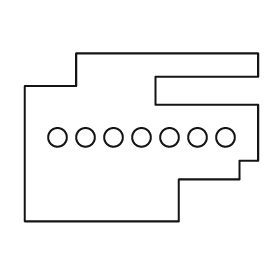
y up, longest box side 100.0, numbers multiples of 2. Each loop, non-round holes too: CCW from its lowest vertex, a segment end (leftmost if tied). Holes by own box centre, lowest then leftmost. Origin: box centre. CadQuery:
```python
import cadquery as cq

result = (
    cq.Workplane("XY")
    .moveTo(-50.0, -36.0)
    .lineTo(16.0, -36.0)
    .lineTo(16.0, -18.0)
    .lineTo(42.0, -18.0)
    .lineTo(42.0, -10.0)
    .lineTo(50.0, -10.0)
    .lineTo(50.0, 14.0)
    .lineTo(6.0, 14.0)
    .lineTo(6.0, 26.0)
    .lineTo(50.0, 26.0)
    .lineTo(50.0, 36.0)
    .lineTo(-28.0, 36.0)
    .lineTo(-28.0, 22.0)
    .lineTo(-50.0, 22.0)
    .close()
    .moveTo(-36.0, 0.0)
    .circle(4.0)
    .moveTo(-24.0, 0.0)
    .circle(4.0)
    .moveTo(-12.0, 0.0)
    .circle(4.0)
    .moveTo(0.0, 0.0)
    .circle(4.0)
    .moveTo(12.0, 0.0)
    .circle(4.0)
    .moveTo(24.0, 0.0)
    .circle(4.0)
    .moveTo(36.0, 0.0)
    .circle(4.0)
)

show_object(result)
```